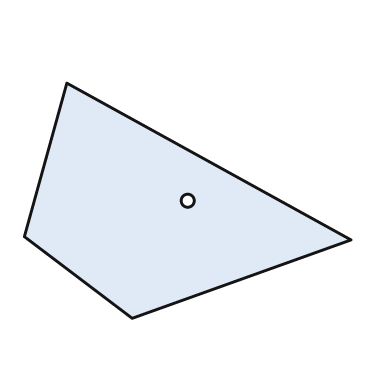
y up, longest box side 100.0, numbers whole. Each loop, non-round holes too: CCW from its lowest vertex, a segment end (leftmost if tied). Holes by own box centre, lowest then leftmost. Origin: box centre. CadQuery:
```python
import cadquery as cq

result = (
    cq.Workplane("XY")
    .moveTo(-17.0, -36.0)
    .lineTo(50.0, -12.0)
    .lineTo(-37.0, 36.0)
    .lineTo(-50.0, -11.0)
    .close()
    .moveTo(0.0, 0.0)
    .circle(2.0)
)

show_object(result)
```